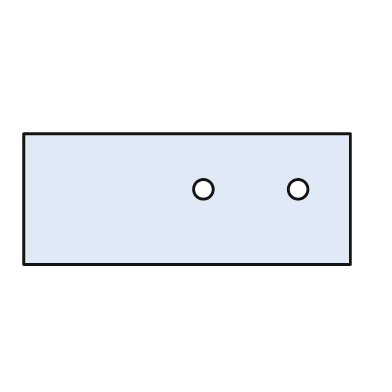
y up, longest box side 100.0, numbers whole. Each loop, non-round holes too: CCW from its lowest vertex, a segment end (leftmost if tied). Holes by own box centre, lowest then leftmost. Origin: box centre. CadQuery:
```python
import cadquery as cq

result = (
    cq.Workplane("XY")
    .moveTo(-50.0, -20.0)
    .lineTo(50.0, -20.0)
    .lineTo(50.0, 20.0)
    .lineTo(-50.0, 20.0)
    .close()
    .moveTo(5.0, 3.0)
    .circle(3.0)
    .moveTo(34.0, 3.0)
    .circle(3.0)
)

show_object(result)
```